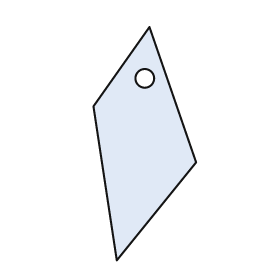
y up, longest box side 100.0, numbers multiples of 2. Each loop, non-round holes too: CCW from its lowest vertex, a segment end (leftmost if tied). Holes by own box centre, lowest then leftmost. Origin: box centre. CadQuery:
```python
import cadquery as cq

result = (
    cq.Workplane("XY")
    .moveTo(-12.0, -50.0)
    .lineTo(22.0, -8.0)
    .lineTo(2.0, 50.0)
    .lineTo(-22.0, 16.0)
    .close()
    .moveTo(0.0, 28.0)
    .circle(4.0)
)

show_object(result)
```